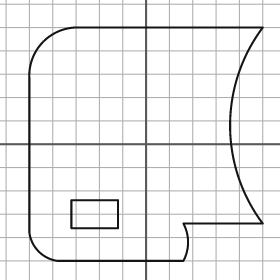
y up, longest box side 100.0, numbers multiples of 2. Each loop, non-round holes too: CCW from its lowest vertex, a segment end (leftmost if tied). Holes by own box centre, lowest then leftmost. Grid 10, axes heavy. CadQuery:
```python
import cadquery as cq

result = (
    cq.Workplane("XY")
    .moveTo(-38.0, -50.0)
    .lineTo(16.0, -50.0)
    .threePointArc((18.0, -42.0), (16.0, -34.0))
    .lineTo(50.0, -34.0)
    .threePointArc((36.0, 8.0), (50.0, 50.0))
    .lineTo(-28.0, 50.0)
    .threePointArc((-44.0, 44.0), (-50.0, 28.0))
    .lineTo(-50.0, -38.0)
    .threePointArc((-46.0, -46.0), (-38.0, -50.0))
    .close()
    .moveTo(-32.0, -36.0)
    .lineTo(-12.0, -36.0)
    .lineTo(-12.0, -24.0)
    .lineTo(-32.0, -24.0)
    .close()
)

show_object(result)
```